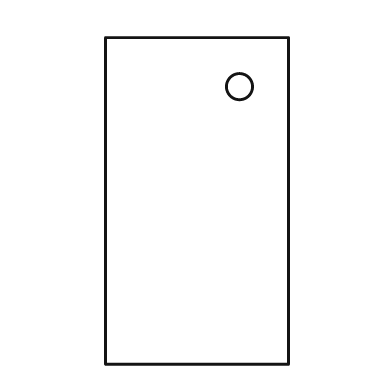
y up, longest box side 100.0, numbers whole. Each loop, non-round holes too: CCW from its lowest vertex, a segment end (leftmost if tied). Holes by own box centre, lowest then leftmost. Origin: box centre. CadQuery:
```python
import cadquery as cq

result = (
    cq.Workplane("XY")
    .moveTo(-28.0, -50.0)
    .lineTo(28.0, -50.0)
    .lineTo(28.0, 50.0)
    .lineTo(-28.0, 50.0)
    .close()
    .moveTo(13.0, 35.0)
    .circle(4.0)
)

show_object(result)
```